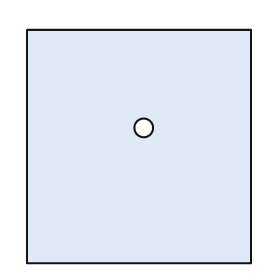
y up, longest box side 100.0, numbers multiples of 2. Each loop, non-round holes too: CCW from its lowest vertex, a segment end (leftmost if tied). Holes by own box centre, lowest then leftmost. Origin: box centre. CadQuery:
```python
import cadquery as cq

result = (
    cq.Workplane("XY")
    .moveTo(-48.0, -50.0)
    .lineTo(48.0, -50.0)
    .lineTo(48.0, 50.0)
    .lineTo(-48.0, 50.0)
    .close()
    .moveTo(2.0, 8.0)
    .circle(4.0)
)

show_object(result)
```